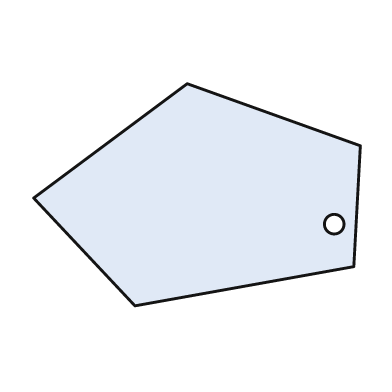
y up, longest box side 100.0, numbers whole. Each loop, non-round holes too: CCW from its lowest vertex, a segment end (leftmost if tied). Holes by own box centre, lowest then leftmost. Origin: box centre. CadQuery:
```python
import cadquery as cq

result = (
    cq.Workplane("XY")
    .moveTo(-19.0, -34.0)
    .lineTo(48.0, -22.0)
    .lineTo(50.0, 15.0)
    .lineTo(-3.0, 34.0)
    .lineTo(-50.0, -1.0)
    .close()
    .moveTo(42.0, -9.0)
    .circle(3.0)
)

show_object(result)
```